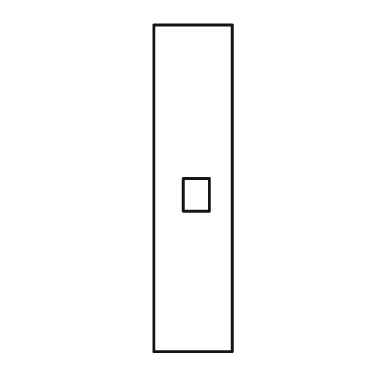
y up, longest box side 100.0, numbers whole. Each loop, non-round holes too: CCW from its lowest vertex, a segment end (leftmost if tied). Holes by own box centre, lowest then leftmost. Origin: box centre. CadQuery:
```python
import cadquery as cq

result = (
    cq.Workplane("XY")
    .moveTo(-12.0, -50.0)
    .lineTo(12.0, -50.0)
    .lineTo(12.0, 50.0)
    .lineTo(-12.0, 50.0)
    .close()
    .moveTo(-3.0, -7.0)
    .lineTo(5.0, -7.0)
    .lineTo(5.0, 3.0)
    .lineTo(-3.0, 3.0)
    .close()
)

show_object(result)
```